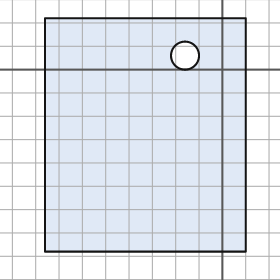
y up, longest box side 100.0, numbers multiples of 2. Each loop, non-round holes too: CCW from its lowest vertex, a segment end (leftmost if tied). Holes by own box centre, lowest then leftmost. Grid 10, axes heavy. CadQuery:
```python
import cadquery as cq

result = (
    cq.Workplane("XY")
    .moveTo(-76.0, -78.0)
    .lineTo(10.0, -78.0)
    .lineTo(10.0, 22.0)
    .lineTo(-76.0, 22.0)
    .close()
    .moveTo(-16.0, 6.0)
    .circle(6.0)
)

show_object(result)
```